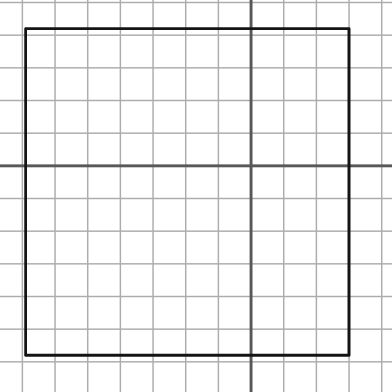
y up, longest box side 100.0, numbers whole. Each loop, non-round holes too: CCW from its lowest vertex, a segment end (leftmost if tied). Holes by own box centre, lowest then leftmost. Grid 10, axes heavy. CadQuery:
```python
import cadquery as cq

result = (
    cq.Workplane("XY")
    .moveTo(-69.0, -58.0)
    .lineTo(30.0, -58.0)
    .lineTo(30.0, 42.0)
    .lineTo(-69.0, 42.0)
    .close()
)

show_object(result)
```